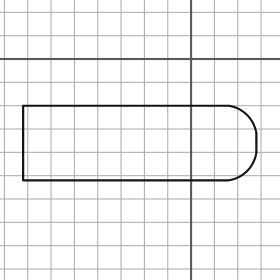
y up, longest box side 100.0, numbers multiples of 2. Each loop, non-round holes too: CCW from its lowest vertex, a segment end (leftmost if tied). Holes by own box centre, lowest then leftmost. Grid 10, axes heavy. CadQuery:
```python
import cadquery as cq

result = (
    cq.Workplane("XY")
    .moveTo(-72.0, -52.0)
    .lineTo(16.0, -52.0)
    .threePointArc((24.0, -48.0), (28.0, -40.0))
    .lineTo(28.0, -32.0)
    .threePointArc((24.0, -24.0), (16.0, -20.0))
    .lineTo(-72.0, -20.0)
    .close()
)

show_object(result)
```